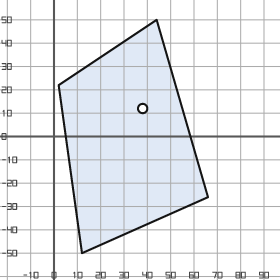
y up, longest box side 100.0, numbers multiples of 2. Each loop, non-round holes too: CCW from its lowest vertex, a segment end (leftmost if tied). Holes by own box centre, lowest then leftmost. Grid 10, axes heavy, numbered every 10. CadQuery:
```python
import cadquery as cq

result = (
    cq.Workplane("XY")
    .moveTo(12.0, -50.0)
    .lineTo(66.0, -26.0)
    .lineTo(44.0, 50.0)
    .lineTo(2.0, 22.0)
    .close()
    .moveTo(38.0, 12.0)
    .circle(2.0)
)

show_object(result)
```